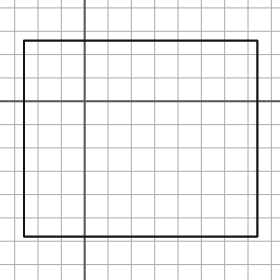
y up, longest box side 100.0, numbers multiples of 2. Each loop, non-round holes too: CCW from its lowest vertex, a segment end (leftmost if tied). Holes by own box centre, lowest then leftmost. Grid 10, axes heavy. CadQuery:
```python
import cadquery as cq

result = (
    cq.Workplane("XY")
    .moveTo(-26.0, -58.0)
    .lineTo(74.0, -58.0)
    .lineTo(74.0, 26.0)
    .lineTo(-26.0, 26.0)
    .close()
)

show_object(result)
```